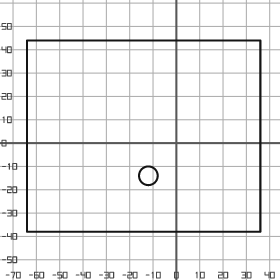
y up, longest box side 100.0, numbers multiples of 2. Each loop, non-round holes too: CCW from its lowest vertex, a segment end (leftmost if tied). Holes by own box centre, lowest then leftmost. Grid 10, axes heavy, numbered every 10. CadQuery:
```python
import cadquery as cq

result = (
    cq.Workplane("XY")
    .moveTo(-64.0, -38.0)
    .lineTo(36.0, -38.0)
    .lineTo(36.0, 44.0)
    .lineTo(-64.0, 44.0)
    .close()
    .moveTo(-12.0, -14.0)
    .circle(4.0)
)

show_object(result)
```